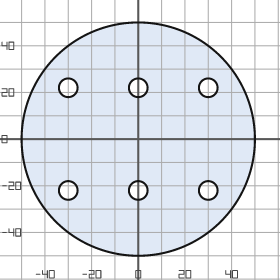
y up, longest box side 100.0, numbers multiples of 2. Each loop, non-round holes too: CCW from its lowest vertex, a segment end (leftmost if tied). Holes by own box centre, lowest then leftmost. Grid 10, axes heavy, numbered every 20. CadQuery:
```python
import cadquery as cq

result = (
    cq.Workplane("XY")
    .moveTo(0.0, 0.0)
    .circle(50.0)
    .moveTo(-30.0, -22.0)
    .circle(4.0)
    .moveTo(0.0, -22.0)
    .circle(4.0)
    .moveTo(30.0, -22.0)
    .circle(4.0)
    .moveTo(-30.0, 22.0)
    .circle(4.0)
    .moveTo(0.0, 22.0)
    .circle(4.0)
    .moveTo(30.0, 22.0)
    .circle(4.0)
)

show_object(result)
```